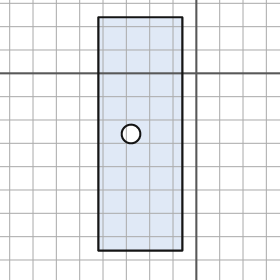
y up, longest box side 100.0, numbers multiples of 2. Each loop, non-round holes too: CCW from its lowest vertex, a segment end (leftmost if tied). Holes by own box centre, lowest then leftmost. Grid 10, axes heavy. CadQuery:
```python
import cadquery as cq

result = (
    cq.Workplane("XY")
    .moveTo(-42.0, -76.0)
    .lineTo(-6.0, -76.0)
    .lineTo(-6.0, 24.0)
    .lineTo(-42.0, 24.0)
    .close()
    .moveTo(-28.0, -26.0)
    .circle(4.0)
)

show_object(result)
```